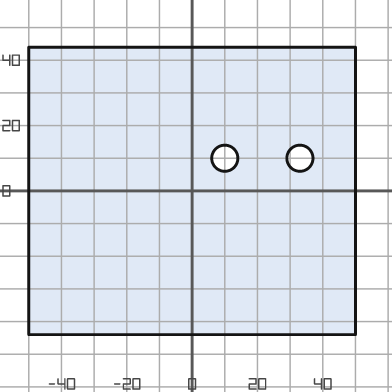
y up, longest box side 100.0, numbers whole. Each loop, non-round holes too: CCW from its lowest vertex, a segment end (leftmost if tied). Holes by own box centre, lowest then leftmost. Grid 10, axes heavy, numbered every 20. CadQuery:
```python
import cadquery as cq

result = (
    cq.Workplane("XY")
    .moveTo(-50.0, -44.0)
    .lineTo(50.0, -44.0)
    .lineTo(50.0, 44.0)
    .lineTo(-50.0, 44.0)
    .close()
    .moveTo(10.0, 10.0)
    .circle(4.0)
    .moveTo(33.0, 10.0)
    .circle(4.0)
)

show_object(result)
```